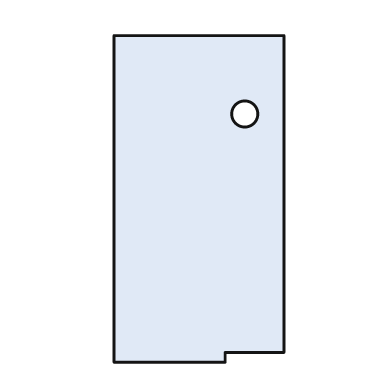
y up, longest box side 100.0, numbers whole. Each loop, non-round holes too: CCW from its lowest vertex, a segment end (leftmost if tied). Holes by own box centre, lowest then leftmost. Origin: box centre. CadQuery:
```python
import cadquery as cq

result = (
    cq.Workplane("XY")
    .moveTo(-26.0, -50.0)
    .lineTo(8.0, -50.0)
    .lineTo(8.0, -47.0)
    .lineTo(26.0, -47.0)
    .lineTo(26.0, 50.0)
    .lineTo(-26.0, 50.0)
    .close()
    .moveTo(14.0, 26.0)
    .circle(4.0)
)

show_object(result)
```